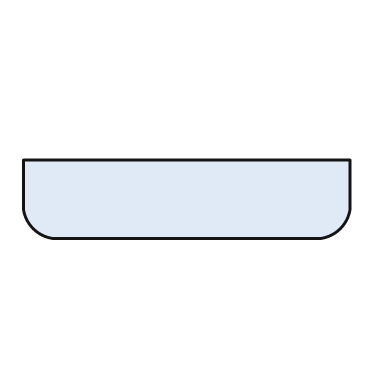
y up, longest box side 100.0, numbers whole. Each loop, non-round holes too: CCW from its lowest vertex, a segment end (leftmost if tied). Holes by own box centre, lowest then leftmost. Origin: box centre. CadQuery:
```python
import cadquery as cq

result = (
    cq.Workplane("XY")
    .moveTo(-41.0, -12.0)
    .lineTo(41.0, -12.0)
    .threePointArc((47.0, -9.0), (50.0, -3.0))
    .lineTo(50.0, 12.0)
    .lineTo(-50.0, 12.0)
    .lineTo(-50.0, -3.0)
    .threePointArc((-47.0, -9.0), (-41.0, -12.0))
    .close()
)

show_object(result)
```